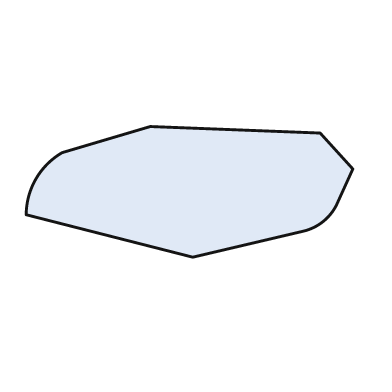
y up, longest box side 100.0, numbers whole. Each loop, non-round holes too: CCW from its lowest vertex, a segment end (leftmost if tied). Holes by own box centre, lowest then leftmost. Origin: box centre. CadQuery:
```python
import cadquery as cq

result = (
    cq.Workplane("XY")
    .moveTo(1.0, -20.0)
    .lineTo(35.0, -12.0)
    .threePointArc((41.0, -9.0), (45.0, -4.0))
    .lineTo(50.0, 7.0)
    .lineTo(40.0, 18.0)
    .lineTo(-12.0, 20.0)
    .lineTo(-39.0, 12.0)
    .threePointArc((-47.0, 4.0), (-50.0, -7.0))
    .close()
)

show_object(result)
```